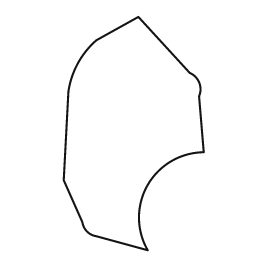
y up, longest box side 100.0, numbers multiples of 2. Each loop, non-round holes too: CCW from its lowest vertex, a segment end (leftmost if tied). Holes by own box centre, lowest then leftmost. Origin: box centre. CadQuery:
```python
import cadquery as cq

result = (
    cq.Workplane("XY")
    .moveTo(6.0, -50.0)
    .threePointArc((6.0, -22.0), (30.0, -8.0))
    .lineTo(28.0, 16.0)
    .threePointArc((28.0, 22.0), (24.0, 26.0))
    .lineTo(2.0, 50.0)
    .lineTo(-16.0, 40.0)
    .threePointArc((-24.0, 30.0), (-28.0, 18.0))
    .lineTo(-30.0, -20.0)
    .lineTo(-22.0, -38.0)
    .threePointArc((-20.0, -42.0), (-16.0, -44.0))
    .close()
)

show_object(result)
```